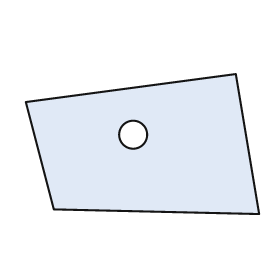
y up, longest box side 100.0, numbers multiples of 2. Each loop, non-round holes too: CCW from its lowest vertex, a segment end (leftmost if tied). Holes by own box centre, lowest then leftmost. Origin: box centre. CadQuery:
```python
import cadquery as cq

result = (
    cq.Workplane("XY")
    .moveTo(50.0, -30.0)
    .lineTo(40.0, 30.0)
    .lineTo(-50.0, 18.0)
    .lineTo(-38.0, -28.0)
    .close()
    .moveTo(-4.0, 4.0)
    .circle(6.0)
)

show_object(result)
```